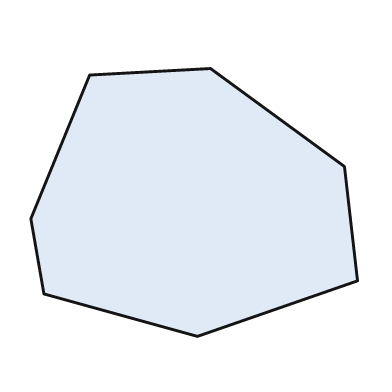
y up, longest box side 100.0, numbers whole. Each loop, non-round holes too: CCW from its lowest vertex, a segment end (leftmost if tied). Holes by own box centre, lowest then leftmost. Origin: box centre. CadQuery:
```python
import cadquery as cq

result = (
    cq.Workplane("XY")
    .moveTo(1.0, -41.0)
    .lineTo(50.0, -24.0)
    .lineTo(46.0, 11.0)
    .lineTo(5.0, 41.0)
    .lineTo(-32.0, 39.0)
    .lineTo(-50.0, -5.0)
    .lineTo(-46.0, -28.0)
    .close()
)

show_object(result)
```